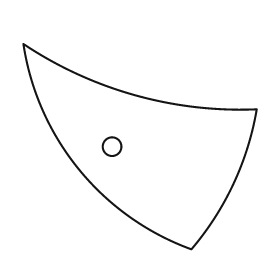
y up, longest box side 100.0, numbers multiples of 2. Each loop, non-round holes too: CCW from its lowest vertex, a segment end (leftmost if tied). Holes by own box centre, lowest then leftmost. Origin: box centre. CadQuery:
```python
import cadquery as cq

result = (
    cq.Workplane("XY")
    .moveTo(22.0, -44.0)
    .threePointArc((40.0, -16.0), (50.0, 16.0))
    .threePointArc((-2.0, 22.0), (-50.0, 44.0))
    .threePointArc((-26.0, -10.0), (22.0, -44.0))
    .close()
    .moveTo(-12.0, 0.0)
    .circle(4.0)
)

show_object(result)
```